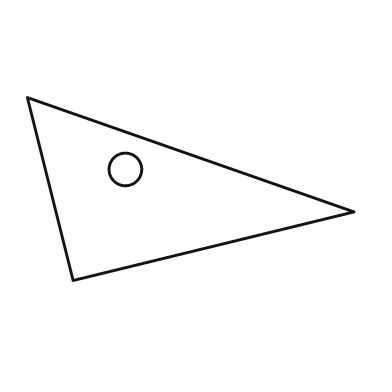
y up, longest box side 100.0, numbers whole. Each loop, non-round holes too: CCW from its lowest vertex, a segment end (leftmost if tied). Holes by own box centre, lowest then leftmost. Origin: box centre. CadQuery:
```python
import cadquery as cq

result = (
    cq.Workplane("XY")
    .moveTo(-36.0, -28.0)
    .lineTo(50.0, -7.0)
    .lineTo(-50.0, 28.0)
    .close()
    .moveTo(-20.0, 6.0)
    .circle(5.0)
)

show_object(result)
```